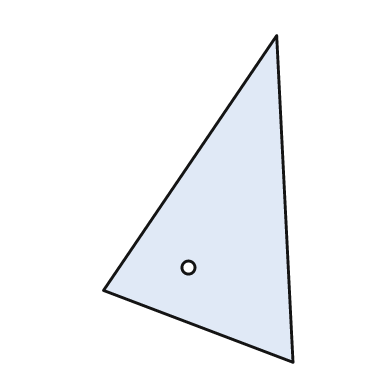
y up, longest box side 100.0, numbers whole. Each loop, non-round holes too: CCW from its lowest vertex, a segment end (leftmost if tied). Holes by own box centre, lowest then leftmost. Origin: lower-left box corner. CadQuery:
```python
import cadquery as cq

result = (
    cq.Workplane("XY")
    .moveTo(58.0, 0.0)
    .lineTo(53.0, 100.0)
    .lineTo(0.0, 22.0)
    .close()
    .moveTo(26.0, 29.0)
    .circle(2.0)
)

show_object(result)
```